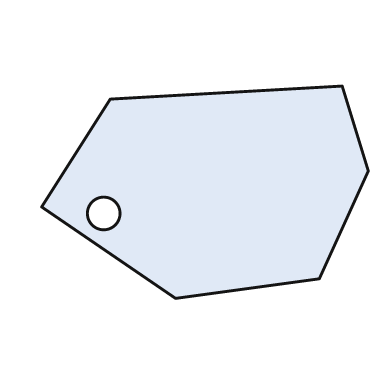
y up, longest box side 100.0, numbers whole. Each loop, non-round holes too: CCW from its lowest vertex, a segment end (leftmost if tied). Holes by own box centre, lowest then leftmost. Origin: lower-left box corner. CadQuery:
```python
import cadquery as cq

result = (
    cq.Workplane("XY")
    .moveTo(41.0, 0.0)
    .lineTo(85.0, 6.0)
    .lineTo(100.0, 39.0)
    .lineTo(92.0, 65.0)
    .lineTo(21.0, 61.0)
    .lineTo(0.0, 28.0)
    .close()
    .moveTo(19.0, 26.0)
    .circle(5.0)
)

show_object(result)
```